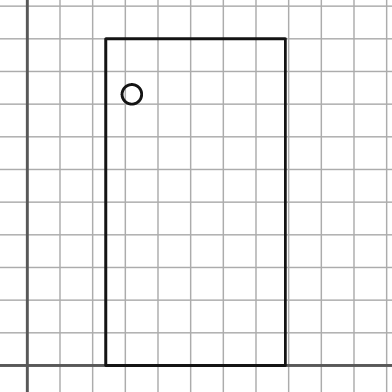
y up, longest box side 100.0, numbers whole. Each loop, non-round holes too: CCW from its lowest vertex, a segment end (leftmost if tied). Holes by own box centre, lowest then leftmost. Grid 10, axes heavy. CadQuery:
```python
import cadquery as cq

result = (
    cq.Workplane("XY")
    .moveTo(24.0, 0.0)
    .lineTo(79.0, 0.0)
    .lineTo(79.0, 100.0)
    .lineTo(24.0, 100.0)
    .close()
    .moveTo(32.0, 83.0)
    .circle(3.0)
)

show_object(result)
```